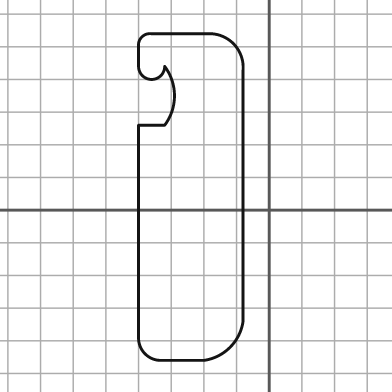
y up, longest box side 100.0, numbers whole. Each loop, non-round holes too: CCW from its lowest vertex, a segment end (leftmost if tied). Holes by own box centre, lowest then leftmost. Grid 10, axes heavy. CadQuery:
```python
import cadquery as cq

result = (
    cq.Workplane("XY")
    .moveTo(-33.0, -46.0)
    .lineTo(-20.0, -46.0)
    .threePointArc((-12.0, -42.0), (-8.0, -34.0))
    .lineTo(-8.0, 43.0)
    .threePointArc((-11.0, 51.0), (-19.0, 54.0))
    .lineTo(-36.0, 54.0)
    .threePointArc((-39.0, 53.0), (-40.0, 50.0))
    .lineTo(-40.0, 44.0)
    .threePointArc((-36.0, 40.0), (-32.0, 44.0))
    .threePointArc((-29.0, 35.0), (-32.0, 26.0))
    .lineTo(-40.0, 26.0)
    .lineTo(-40.0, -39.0)
    .threePointArc((-38.0, -44.0), (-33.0, -46.0))
    .close()
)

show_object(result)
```